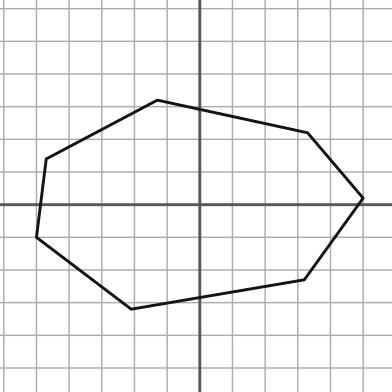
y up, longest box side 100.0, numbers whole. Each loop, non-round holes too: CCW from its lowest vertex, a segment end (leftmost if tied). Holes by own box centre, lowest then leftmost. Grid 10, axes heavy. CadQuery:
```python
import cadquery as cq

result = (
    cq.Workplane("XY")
    .moveTo(-21.0, -32.0)
    .lineTo(32.0, -23.0)
    .lineTo(50.0, 2.0)
    .lineTo(33.0, 22.0)
    .lineTo(-13.0, 32.0)
    .lineTo(-47.0, 14.0)
    .lineTo(-50.0, -10.0)
    .close()
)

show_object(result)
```